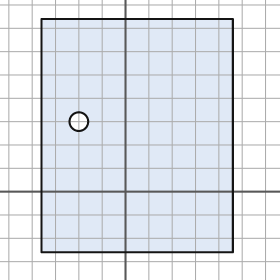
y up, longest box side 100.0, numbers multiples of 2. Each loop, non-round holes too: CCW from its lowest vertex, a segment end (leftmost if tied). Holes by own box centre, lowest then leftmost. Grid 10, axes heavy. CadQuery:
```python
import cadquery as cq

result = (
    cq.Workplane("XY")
    .moveTo(-36.0, -26.0)
    .lineTo(46.0, -26.0)
    .lineTo(46.0, 74.0)
    .lineTo(-36.0, 74.0)
    .close()
    .moveTo(-20.0, 30.0)
    .circle(4.0)
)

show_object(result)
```